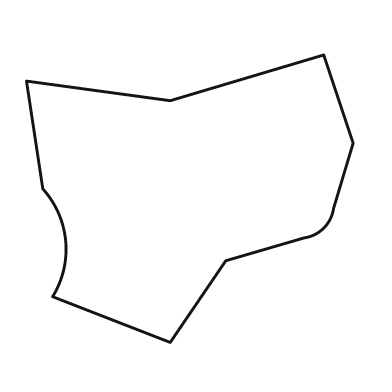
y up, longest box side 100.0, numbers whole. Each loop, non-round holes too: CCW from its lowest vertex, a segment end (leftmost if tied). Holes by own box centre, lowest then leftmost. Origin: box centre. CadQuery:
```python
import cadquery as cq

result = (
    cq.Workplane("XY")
    .moveTo(-6.0, -44.0)
    .lineTo(11.0, -19.0)
    .lineTo(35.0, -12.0)
    .threePointArc((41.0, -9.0), (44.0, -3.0))
    .lineTo(50.0, 17.0)
    .lineTo(41.0, 44.0)
    .lineTo(-6.0, 30.0)
    .lineTo(-50.0, 36.0)
    .lineTo(-45.0, 3.0)
    .threePointArc((-38.0, -13.0), (-42.0, -30.0))
    .close()
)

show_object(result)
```